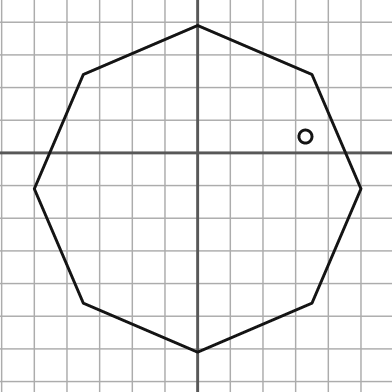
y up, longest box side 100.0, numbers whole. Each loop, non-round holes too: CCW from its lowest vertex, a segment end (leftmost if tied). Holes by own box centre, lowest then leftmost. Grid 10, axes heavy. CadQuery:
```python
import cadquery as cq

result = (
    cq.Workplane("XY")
    .moveTo(0.0, -61.0)
    .lineTo(35.0, -46.0)
    .lineTo(50.0, -11.0)
    .lineTo(35.0, 24.0)
    .lineTo(0.0, 39.0)
    .lineTo(-35.0, 24.0)
    .lineTo(-50.0, -11.0)
    .lineTo(-35.0, -46.0)
    .close()
    .moveTo(33.0, 5.0)
    .circle(2.0)
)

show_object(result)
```